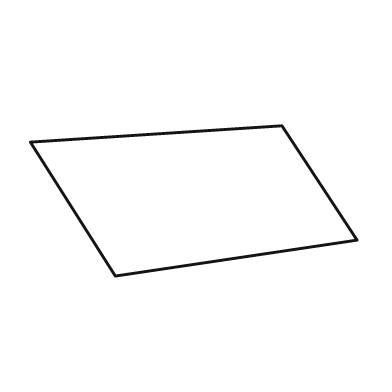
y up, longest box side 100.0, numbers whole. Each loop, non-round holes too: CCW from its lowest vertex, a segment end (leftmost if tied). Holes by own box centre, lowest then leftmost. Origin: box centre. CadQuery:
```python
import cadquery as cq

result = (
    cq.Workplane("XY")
    .moveTo(-24.0, -23.0)
    .lineTo(50.0, -12.0)
    .lineTo(27.0, 23.0)
    .lineTo(-50.0, 18.0)
    .close()
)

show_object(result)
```